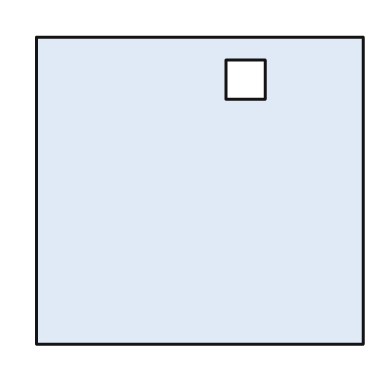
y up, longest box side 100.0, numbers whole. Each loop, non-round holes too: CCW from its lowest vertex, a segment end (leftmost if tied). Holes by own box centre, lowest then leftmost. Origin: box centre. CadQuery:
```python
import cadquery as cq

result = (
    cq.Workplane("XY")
    .moveTo(-50.0, -47.0)
    .lineTo(50.0, -47.0)
    .lineTo(50.0, 47.0)
    .lineTo(-50.0, 47.0)
    .close()
    .moveTo(8.0, 28.0)
    .lineTo(20.0, 28.0)
    .lineTo(20.0, 40.0)
    .lineTo(8.0, 40.0)
    .close()
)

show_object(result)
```